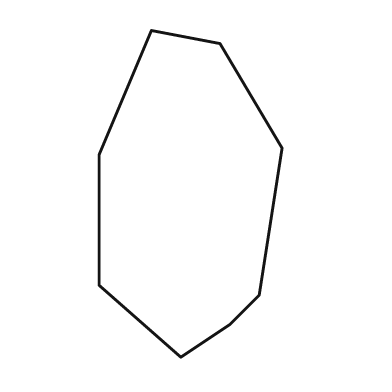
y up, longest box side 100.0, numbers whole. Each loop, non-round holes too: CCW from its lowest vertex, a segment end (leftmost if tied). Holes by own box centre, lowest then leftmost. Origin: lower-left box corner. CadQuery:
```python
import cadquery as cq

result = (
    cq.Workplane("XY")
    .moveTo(25.0, 0.0)
    .lineTo(40.0, 10.0)
    .lineTo(49.0, 19.0)
    .lineTo(56.0, 64.0)
    .lineTo(37.0, 96.0)
    .lineTo(16.0, 100.0)
    .lineTo(0.0, 62.0)
    .lineTo(0.0, 22.0)
    .close()
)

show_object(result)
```